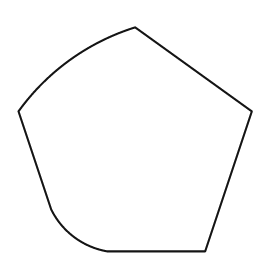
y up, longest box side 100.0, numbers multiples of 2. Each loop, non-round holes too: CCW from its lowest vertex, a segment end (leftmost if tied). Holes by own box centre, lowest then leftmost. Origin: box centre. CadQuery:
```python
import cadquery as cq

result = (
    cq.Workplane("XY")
    .moveTo(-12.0, -48.0)
    .lineTo(30.0, -48.0)
    .lineTo(50.0, 12.0)
    .lineTo(0.0, 48.0)
    .threePointArc((-28.0, 34.0), (-50.0, 12.0))
    .lineTo(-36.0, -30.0)
    .threePointArc((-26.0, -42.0), (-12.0, -48.0))
    .close()
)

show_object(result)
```